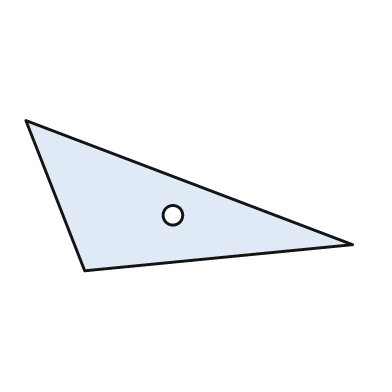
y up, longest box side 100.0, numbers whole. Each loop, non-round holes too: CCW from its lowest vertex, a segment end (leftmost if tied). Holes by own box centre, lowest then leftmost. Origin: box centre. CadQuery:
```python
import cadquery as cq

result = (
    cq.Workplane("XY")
    .moveTo(-32.0, -23.0)
    .lineTo(50.0, -15.0)
    .lineTo(-50.0, 23.0)
    .close()
    .moveTo(-5.0, -6.0)
    .circle(3.0)
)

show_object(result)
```